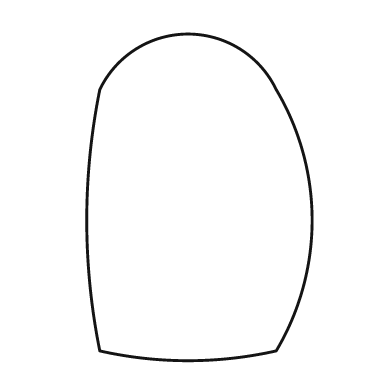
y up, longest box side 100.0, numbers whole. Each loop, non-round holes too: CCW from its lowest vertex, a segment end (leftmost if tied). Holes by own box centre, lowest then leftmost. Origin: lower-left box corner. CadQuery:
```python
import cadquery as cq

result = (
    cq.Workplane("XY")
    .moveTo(4.0, 3.0)
    .threePointArc((31.0, 0.0), (58.0, 3.0))
    .threePointArc((69.0, 43.0), (58.0, 83.0))
    .threePointArc((31.0, 100.0), (4.0, 83.0))
    .threePointArc((0.0, 43.0), (4.0, 3.0))
    .close()
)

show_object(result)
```